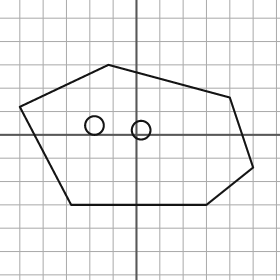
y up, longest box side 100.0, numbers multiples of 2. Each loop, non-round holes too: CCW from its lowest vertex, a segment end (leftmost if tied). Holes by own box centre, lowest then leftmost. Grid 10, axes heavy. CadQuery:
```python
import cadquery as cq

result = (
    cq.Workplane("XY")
    .moveTo(-28.0, -30.0)
    .lineTo(30.0, -30.0)
    .lineTo(50.0, -14.0)
    .lineTo(40.0, 16.0)
    .lineTo(-12.0, 30.0)
    .lineTo(-50.0, 12.0)
    .close()
    .moveTo(2.0, 2.0)
    .circle(4.0)
    .moveTo(-18.0, 4.0)
    .circle(4.0)
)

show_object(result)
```